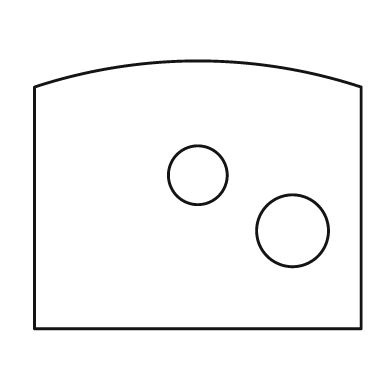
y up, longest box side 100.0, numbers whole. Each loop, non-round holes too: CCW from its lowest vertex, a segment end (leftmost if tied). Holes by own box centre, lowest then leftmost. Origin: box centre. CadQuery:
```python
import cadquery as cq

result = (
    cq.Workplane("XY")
    .moveTo(-50.0, -41.0)
    .lineTo(50.0, -41.0)
    .lineTo(50.0, 33.0)
    .threePointArc((0.0, 41.0), (-50.0, 33.0))
    .close()
    .moveTo(29.0, -11.0)
    .circle(11.0)
    .moveTo(0.0, 6.0)
    .circle(9.0)
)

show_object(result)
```